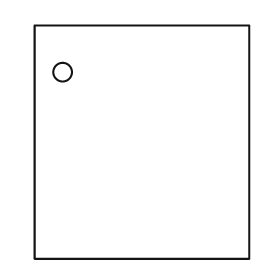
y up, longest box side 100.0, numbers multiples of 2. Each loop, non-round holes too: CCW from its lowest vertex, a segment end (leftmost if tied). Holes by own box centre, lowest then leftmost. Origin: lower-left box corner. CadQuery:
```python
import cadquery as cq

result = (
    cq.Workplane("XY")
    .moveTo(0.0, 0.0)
    .lineTo(92.0, 0.0)
    .lineTo(92.0, 100.0)
    .lineTo(0.0, 100.0)
    .close()
    .moveTo(12.0, 80.0)
    .circle(4.0)
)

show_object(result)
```